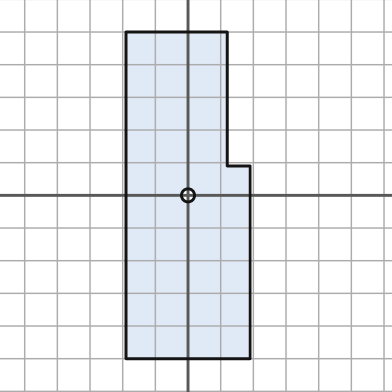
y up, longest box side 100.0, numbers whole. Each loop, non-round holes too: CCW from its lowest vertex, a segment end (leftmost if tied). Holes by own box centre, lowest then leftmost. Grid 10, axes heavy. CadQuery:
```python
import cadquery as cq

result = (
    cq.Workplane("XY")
    .moveTo(-19.0, -50.0)
    .lineTo(19.0, -50.0)
    .lineTo(19.0, 9.0)
    .lineTo(12.0, 9.0)
    .lineTo(12.0, 50.0)
    .lineTo(-19.0, 50.0)
    .close()
    .moveTo(0.0, 0.0)
    .circle(2.0)
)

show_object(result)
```